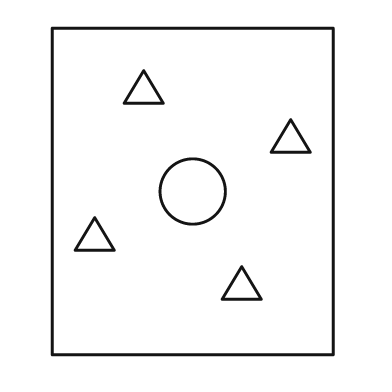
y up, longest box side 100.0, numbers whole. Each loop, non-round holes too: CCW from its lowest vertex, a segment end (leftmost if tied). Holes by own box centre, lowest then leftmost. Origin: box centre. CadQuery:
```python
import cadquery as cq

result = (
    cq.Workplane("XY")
    .moveTo(-43.0, -50.0)
    .lineTo(43.0, -50.0)
    .lineTo(43.0, 50.0)
    .lineTo(-43.0, 50.0)
    .close()
    .moveTo(9.0, -33.0)
    .lineTo(21.0, -33.0)
    .lineTo(15.0, -23.0)
    .close()
    .moveTo(-36.0, -18.0)
    .lineTo(-24.0, -18.0)
    .lineTo(-30.0, -8.0)
    .close()
    .moveTo(0.0, 0.0)
    .circle(10.0)
    .moveTo(24.0, 12.0)
    .lineTo(36.0, 12.0)
    .lineTo(30.0, 22.0)
    .close()
    .moveTo(-21.0, 27.0)
    .lineTo(-9.0, 27.0)
    .lineTo(-15.0, 37.0)
    .close()
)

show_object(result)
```